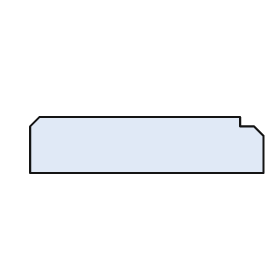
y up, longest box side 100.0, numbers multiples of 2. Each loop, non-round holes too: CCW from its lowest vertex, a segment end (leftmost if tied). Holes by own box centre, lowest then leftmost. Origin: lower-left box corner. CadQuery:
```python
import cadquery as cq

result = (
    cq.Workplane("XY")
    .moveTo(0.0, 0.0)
    .lineTo(100.0, 0.0)
    .lineTo(100.0, 16.0)
    .lineTo(96.0, 20.0)
    .lineTo(90.0, 20.0)
    .lineTo(90.0, 24.0)
    .lineTo(4.0, 24.0)
    .lineTo(0.0, 20.0)
    .close()
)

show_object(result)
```